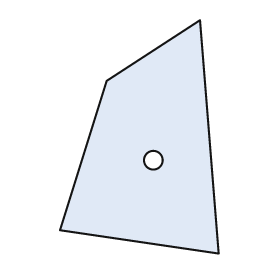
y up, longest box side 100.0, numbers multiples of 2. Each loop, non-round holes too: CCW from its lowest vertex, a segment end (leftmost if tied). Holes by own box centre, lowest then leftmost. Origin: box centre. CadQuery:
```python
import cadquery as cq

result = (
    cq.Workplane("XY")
    .moveTo(34.0, -50.0)
    .lineTo(26.0, 50.0)
    .lineTo(-14.0, 24.0)
    .lineTo(-34.0, -40.0)
    .close()
    .moveTo(6.0, -10.0)
    .circle(4.0)
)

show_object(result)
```